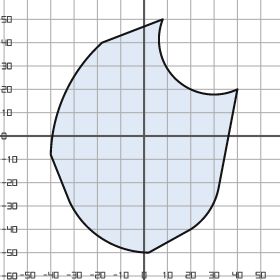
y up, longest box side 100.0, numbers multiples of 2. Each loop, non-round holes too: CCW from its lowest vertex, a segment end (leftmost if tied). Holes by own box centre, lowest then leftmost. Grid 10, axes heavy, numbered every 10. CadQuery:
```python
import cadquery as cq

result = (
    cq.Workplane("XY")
    .moveTo(2.0, -50.0)
    .lineTo(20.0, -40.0)
    .threePointArc((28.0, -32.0), (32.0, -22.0))
    .lineTo(40.0, 20.0)
    .threePointArc((14.0, 24.0), (8.0, 50.0))
    .lineTo(-18.0, 40.0)
    .threePointArc((-34.0, 18.0), (-40.0, -8.0))
    .lineTo(-32.0, -28.0)
    .threePointArc((-18.0, -44.0), (2.0, -50.0))
    .close()
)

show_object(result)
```